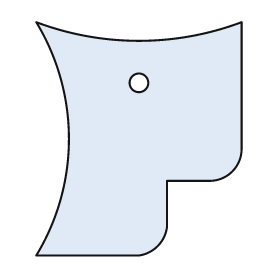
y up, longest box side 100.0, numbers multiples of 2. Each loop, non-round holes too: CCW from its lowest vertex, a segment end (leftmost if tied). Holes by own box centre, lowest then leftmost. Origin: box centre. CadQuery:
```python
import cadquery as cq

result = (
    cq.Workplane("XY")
    .moveTo(-44.0, -50.0)
    .lineTo(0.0, -50.0)
    .threePointArc((8.0, -46.0), (12.0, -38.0))
    .lineTo(12.0, -18.0)
    .lineTo(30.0, -18.0)
    .threePointArc((40.0, -14.0), (44.0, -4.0))
    .lineTo(44.0, 50.0)
    .threePointArc((0.0, 42.0), (-44.0, 50.0))
    .threePointArc((-30.0, 0.0), (-44.0, -50.0))
    .close()
    .moveTo(0.0, 24.0)
    .circle(4.0)
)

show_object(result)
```